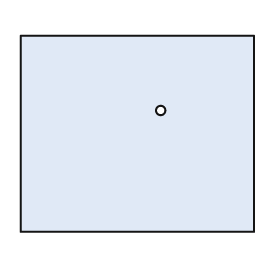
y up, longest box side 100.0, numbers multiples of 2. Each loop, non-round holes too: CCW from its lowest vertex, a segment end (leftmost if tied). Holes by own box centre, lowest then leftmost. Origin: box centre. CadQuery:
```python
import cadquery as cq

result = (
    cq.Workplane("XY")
    .moveTo(-50.0, -42.0)
    .lineTo(50.0, -42.0)
    .lineTo(50.0, 42.0)
    .lineTo(-50.0, 42.0)
    .close()
    .moveTo(10.0, 10.0)
    .circle(2.0)
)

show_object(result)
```